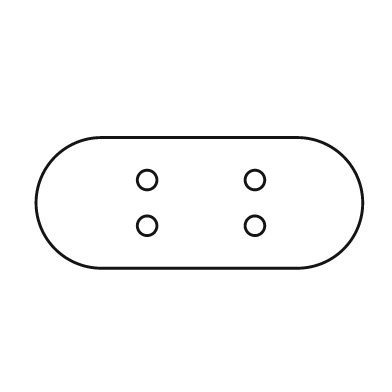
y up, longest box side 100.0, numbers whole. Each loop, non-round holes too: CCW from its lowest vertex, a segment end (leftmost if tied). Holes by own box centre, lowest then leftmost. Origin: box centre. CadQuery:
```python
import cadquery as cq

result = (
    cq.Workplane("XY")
    .moveTo(-30.0, -20.0)
    .lineTo(30.0, -20.0)
    .threePointArc((50.0, 0.0), (30.0, 20.0))
    .lineTo(-30.0, 20.0)
    .threePointArc((-50.0, 0.0), (-30.0, -20.0))
    .close()
    .moveTo(-16.0, -7.0)
    .circle(3.0)
    .moveTo(17.0, -7.0)
    .circle(3.0)
    .moveTo(-16.0, 7.0)
    .circle(3.0)
    .moveTo(17.0, 7.0)
    .circle(3.0)
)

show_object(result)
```